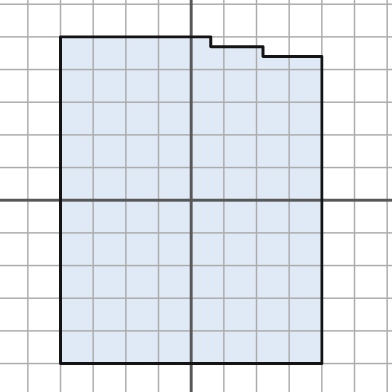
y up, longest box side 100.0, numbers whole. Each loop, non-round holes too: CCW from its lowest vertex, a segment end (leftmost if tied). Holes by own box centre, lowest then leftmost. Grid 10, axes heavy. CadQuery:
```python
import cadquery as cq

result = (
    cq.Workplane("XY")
    .moveTo(-40.0, -50.0)
    .lineTo(40.0, -50.0)
    .lineTo(40.0, 44.0)
    .lineTo(22.0, 44.0)
    .lineTo(22.0, 47.0)
    .lineTo(6.0, 47.0)
    .lineTo(6.0, 50.0)
    .lineTo(-40.0, 50.0)
    .close()
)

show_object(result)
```